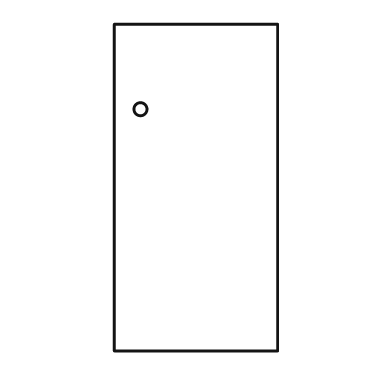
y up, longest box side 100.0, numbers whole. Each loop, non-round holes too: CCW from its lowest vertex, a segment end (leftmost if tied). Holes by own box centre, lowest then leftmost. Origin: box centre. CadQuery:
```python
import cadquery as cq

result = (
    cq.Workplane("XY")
    .moveTo(-25.0, -50.0)
    .lineTo(25.0, -50.0)
    .lineTo(25.0, 50.0)
    .lineTo(-25.0, 50.0)
    .close()
    .moveTo(-17.0, 24.0)
    .circle(2.0)
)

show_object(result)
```